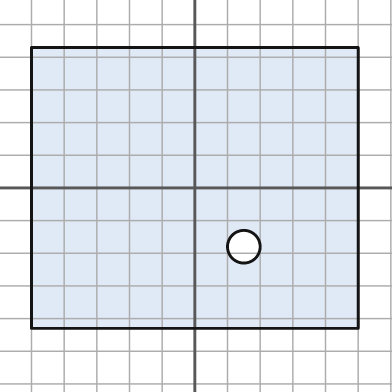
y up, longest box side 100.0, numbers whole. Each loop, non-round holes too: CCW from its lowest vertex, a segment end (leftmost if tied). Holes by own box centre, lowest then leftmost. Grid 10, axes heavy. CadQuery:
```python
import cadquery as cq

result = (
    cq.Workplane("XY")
    .moveTo(-50.0, -43.0)
    .lineTo(50.0, -43.0)
    .lineTo(50.0, 43.0)
    .lineTo(-50.0, 43.0)
    .close()
    .moveTo(15.0, -18.0)
    .circle(5.0)
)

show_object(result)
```